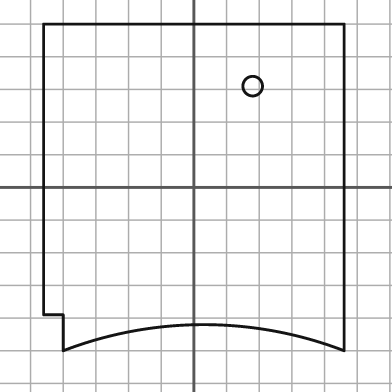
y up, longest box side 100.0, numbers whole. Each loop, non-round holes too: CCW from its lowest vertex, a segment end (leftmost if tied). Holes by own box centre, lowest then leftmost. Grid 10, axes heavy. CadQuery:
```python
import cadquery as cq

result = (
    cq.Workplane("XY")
    .moveTo(-40.0, -50.0)
    .threePointArc((3.0, -42.0), (46.0, -50.0))
    .lineTo(46.0, 50.0)
    .lineTo(-46.0, 50.0)
    .lineTo(-46.0, -39.0)
    .lineTo(-40.0, -39.0)
    .close()
    .moveTo(18.0, 31.0)
    .circle(3.0)
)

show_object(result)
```